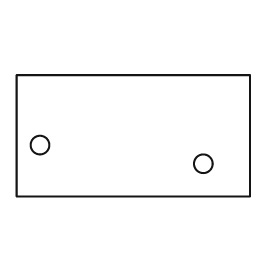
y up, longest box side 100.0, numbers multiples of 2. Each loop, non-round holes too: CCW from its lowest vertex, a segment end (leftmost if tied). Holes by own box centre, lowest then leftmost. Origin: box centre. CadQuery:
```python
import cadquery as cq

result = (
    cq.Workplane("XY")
    .moveTo(-50.0, -26.0)
    .lineTo(50.0, -26.0)
    .lineTo(50.0, 26.0)
    .lineTo(-50.0, 26.0)
    .close()
    .moveTo(30.0, -12.0)
    .circle(4.0)
    .moveTo(-40.0, -4.0)
    .circle(4.0)
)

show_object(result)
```